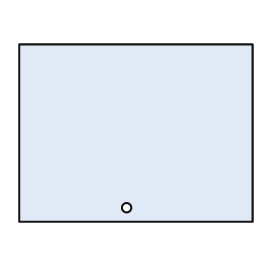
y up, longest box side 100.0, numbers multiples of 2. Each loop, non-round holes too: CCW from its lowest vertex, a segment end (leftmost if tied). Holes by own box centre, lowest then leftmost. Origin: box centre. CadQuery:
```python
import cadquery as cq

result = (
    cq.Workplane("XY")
    .moveTo(-50.0, -38.0)
    .lineTo(50.0, -38.0)
    .lineTo(50.0, 38.0)
    .lineTo(-50.0, 38.0)
    .close()
    .moveTo(-4.0, -32.0)
    .circle(2.0)
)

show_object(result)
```